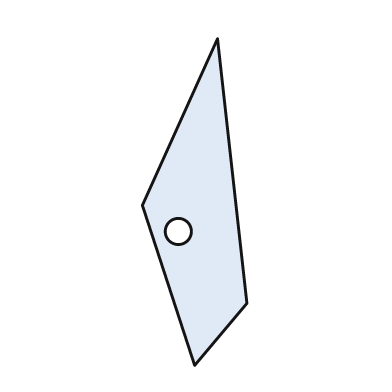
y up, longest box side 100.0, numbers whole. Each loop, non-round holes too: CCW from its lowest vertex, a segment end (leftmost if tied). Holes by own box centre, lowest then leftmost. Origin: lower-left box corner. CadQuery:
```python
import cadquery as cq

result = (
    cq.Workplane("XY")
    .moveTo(16.0, 0.0)
    .lineTo(32.0, 19.0)
    .lineTo(23.0, 100.0)
    .lineTo(0.0, 49.0)
    .close()
    .moveTo(11.0, 41.0)
    .circle(4.0)
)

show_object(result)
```